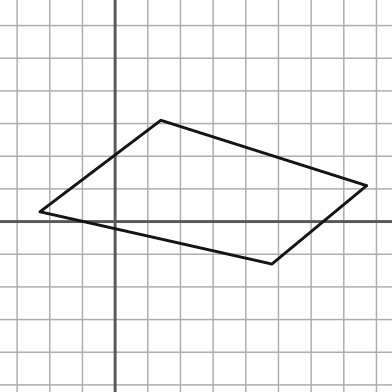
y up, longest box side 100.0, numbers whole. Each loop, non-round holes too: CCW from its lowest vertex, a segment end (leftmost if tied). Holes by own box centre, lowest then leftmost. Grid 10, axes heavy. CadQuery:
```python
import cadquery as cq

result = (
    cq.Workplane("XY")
    .moveTo(48.0, -13.0)
    .lineTo(77.0, 11.0)
    .lineTo(14.0, 31.0)
    .lineTo(-23.0, 3.0)
    .close()
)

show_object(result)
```